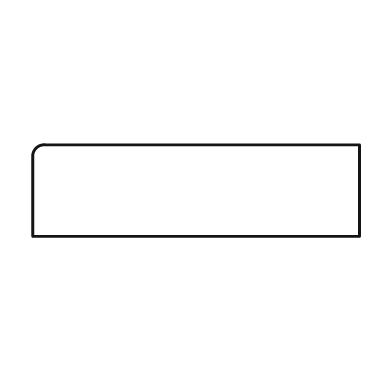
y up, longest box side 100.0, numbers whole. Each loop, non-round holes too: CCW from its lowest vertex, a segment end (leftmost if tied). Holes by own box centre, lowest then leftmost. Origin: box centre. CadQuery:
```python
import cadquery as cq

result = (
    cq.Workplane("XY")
    .moveTo(-50.0, -14.0)
    .lineTo(50.0, -14.0)
    .lineTo(50.0, 14.0)
    .lineTo(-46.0, 14.0)
    .threePointArc((-49.0, 13.0), (-50.0, 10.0))
    .close()
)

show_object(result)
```